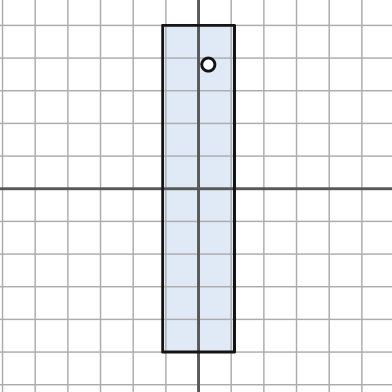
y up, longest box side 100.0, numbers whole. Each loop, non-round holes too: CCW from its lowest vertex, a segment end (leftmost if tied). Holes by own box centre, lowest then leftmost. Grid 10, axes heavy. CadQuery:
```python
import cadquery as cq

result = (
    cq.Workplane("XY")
    .moveTo(-11.0, -50.0)
    .lineTo(11.0, -50.0)
    .lineTo(11.0, 50.0)
    .lineTo(-11.0, 50.0)
    .close()
    .moveTo(3.0, 38.0)
    .circle(2.0)
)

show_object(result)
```